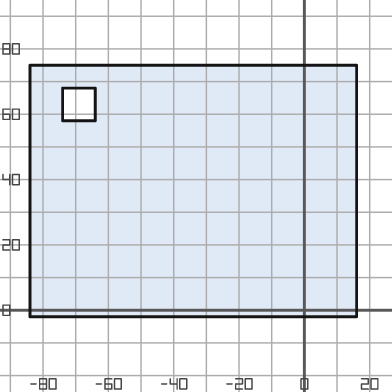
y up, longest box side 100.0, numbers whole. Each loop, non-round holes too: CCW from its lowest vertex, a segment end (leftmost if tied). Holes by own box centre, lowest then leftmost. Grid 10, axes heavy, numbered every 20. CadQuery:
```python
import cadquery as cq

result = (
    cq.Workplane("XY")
    .moveTo(-84.0, -2.0)
    .lineTo(16.0, -2.0)
    .lineTo(16.0, 75.0)
    .lineTo(-84.0, 75.0)
    .close()
    .moveTo(-74.0, 58.0)
    .lineTo(-64.0, 58.0)
    .lineTo(-64.0, 68.0)
    .lineTo(-74.0, 68.0)
    .close()
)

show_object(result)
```